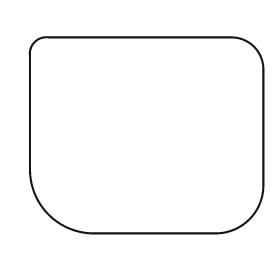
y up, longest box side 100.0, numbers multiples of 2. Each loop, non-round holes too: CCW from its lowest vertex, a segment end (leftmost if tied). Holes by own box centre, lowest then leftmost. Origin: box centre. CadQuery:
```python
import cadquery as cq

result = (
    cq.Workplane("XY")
    .moveTo(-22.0, -42.0)
    .lineTo(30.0, -42.0)
    .threePointArc((44.0, -36.0), (50.0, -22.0))
    .lineTo(50.0, 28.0)
    .threePointArc((46.0, 38.0), (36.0, 42.0))
    .lineTo(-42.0, 42.0)
    .threePointArc((-48.0, 40.0), (-50.0, 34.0))
    .lineTo(-50.0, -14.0)
    .threePointArc((-42.0, -34.0), (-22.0, -42.0))
    .close()
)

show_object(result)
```